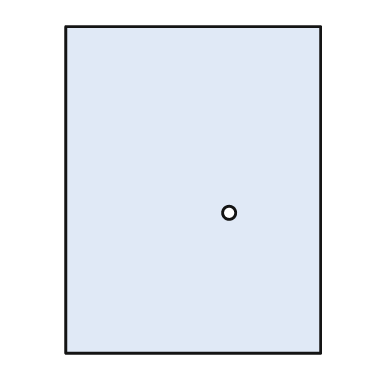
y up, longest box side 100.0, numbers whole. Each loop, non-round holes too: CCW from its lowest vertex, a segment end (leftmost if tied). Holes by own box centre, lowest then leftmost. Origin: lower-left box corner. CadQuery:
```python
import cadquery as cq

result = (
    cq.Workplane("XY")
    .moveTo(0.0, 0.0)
    .lineTo(78.0, 0.0)
    .lineTo(78.0, 100.0)
    .lineTo(0.0, 100.0)
    .close()
    .moveTo(50.0, 43.0)
    .circle(2.0)
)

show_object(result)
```